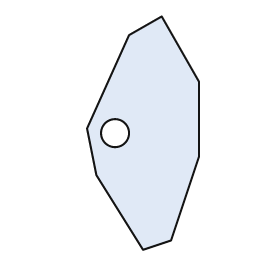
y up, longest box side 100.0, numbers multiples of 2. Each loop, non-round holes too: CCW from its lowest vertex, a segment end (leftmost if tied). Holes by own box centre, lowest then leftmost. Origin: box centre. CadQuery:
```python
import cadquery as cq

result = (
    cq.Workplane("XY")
    .moveTo(0.0, -50.0)
    .lineTo(12.0, -46.0)
    .lineTo(24.0, -10.0)
    .lineTo(24.0, 22.0)
    .lineTo(8.0, 50.0)
    .lineTo(-6.0, 42.0)
    .lineTo(-24.0, 2.0)
    .lineTo(-20.0, -18.0)
    .close()
    .moveTo(-12.0, 0.0)
    .circle(6.0)
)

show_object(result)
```